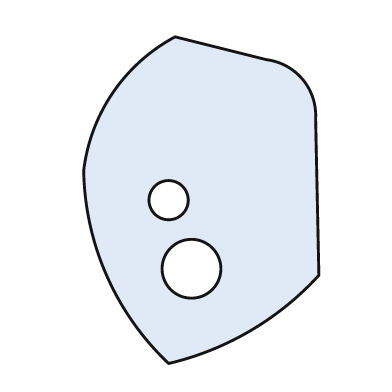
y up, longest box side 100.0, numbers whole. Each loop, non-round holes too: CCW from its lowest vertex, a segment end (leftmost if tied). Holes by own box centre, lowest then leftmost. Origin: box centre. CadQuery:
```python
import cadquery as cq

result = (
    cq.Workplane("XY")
    .moveTo(-10.0, -50.0)
    .threePointArc((15.0, -40.0), (36.0, -23.0))
    .lineTo(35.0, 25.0)
    .threePointArc((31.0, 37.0), (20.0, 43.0))
    .lineTo(-8.0, 50.0)
    .threePointArc((-27.0, 33.0), (-36.0, 9.0))
    .threePointArc((-29.0, -23.0), (-10.0, -50.0))
    .close()
    .moveTo(-3.0, -21.0)
    .circle(9.0)
    .moveTo(-10.0, 0.0)
    .circle(6.0)
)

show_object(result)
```